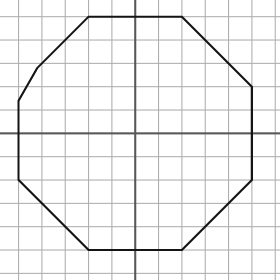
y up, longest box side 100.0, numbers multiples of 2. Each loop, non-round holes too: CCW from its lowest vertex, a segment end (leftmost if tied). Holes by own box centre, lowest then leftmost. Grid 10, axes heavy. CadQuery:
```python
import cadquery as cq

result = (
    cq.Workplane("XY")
    .moveTo(-20.0, -50.0)
    .lineTo(20.0, -50.0)
    .lineTo(50.0, -20.0)
    .lineTo(50.0, 20.0)
    .lineTo(20.0, 50.0)
    .lineTo(-20.0, 50.0)
    .lineTo(-42.0, 28.0)
    .lineTo(-50.0, 14.0)
    .lineTo(-50.0, -20.0)
    .close()
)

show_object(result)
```